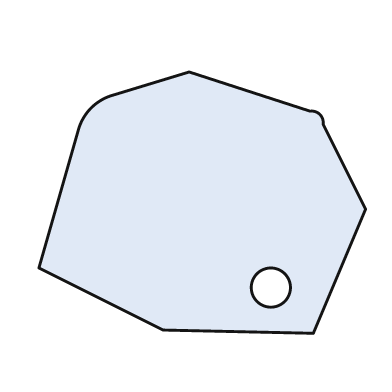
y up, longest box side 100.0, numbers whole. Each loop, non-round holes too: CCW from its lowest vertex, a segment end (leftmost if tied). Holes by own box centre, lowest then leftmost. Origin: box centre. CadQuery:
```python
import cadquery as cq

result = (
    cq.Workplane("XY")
    .moveTo(34.0, -40.0)
    .lineTo(50.0, -2.0)
    .lineTo(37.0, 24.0)
    .threePointArc((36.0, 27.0), (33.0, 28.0))
    .lineTo(-4.0, 40.0)
    .lineTo(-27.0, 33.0)
    .threePointArc((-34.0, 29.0), (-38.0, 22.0))
    .lineTo(-50.0, -20.0)
    .lineTo(-12.0, -39.0)
    .close()
    .moveTo(21.0, -26.0)
    .circle(6.0)
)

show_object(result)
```